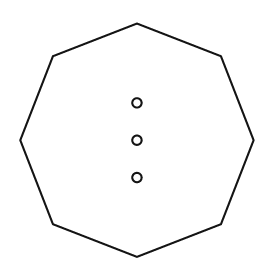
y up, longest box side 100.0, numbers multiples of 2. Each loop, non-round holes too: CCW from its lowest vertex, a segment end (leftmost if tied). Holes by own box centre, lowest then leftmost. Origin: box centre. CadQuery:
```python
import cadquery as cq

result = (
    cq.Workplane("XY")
    .moveTo(0.0, -50.0)
    .lineTo(36.0, -36.0)
    .lineTo(50.0, 0.0)
    .lineTo(36.0, 36.0)
    .lineTo(0.0, 50.0)
    .lineTo(-36.0, 36.0)
    .lineTo(-50.0, 0.0)
    .lineTo(-36.0, -36.0)
    .close()
    .moveTo(0.0, -16.0)
    .circle(2.0)
    .moveTo(0.0, 0.0)
    .circle(2.0)
    .moveTo(0.0, 16.0)
    .circle(2.0)
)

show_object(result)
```